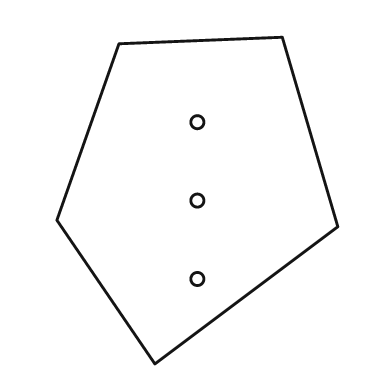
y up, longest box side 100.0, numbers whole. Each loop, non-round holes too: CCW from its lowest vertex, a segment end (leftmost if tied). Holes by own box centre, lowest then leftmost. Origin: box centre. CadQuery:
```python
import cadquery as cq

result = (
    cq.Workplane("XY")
    .moveTo(-13.0, -50.0)
    .lineTo(43.0, -8.0)
    .lineTo(26.0, 50.0)
    .lineTo(-24.0, 48.0)
    .lineTo(-43.0, -6.0)
    .close()
    .moveTo(0.0, -24.0)
    .circle(2.0)
    .moveTo(0.0, 0.0)
    .circle(2.0)
    .moveTo(0.0, 24.0)
    .circle(2.0)
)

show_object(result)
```